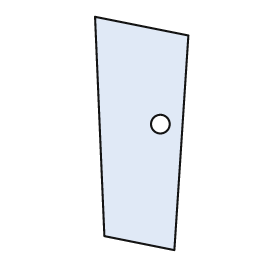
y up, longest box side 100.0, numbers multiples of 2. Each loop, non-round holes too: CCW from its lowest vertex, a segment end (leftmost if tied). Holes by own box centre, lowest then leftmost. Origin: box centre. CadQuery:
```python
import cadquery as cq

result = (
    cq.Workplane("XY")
    .moveTo(14.0, -50.0)
    .lineTo(20.0, 42.0)
    .lineTo(-20.0, 50.0)
    .lineTo(-16.0, -44.0)
    .close()
    .moveTo(8.0, 4.0)
    .circle(4.0)
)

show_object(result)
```